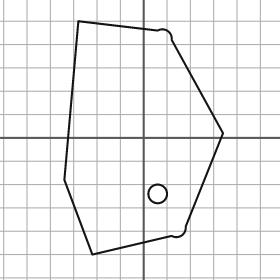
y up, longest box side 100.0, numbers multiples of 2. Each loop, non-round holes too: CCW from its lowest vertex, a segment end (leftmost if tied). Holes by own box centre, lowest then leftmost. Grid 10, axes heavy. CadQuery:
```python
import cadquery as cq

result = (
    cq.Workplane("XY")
    .moveTo(-22.0, -50.0)
    .lineTo(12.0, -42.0)
    .threePointArc((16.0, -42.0), (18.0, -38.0))
    .lineTo(34.0, 2.0)
    .lineTo(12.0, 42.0)
    .threePointArc((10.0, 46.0), (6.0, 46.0))
    .lineTo(-28.0, 50.0)
    .lineTo(-34.0, -18.0)
    .close()
    .moveTo(6.0, -24.0)
    .circle(4.0)
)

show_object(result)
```